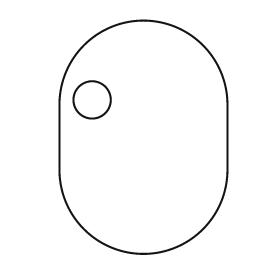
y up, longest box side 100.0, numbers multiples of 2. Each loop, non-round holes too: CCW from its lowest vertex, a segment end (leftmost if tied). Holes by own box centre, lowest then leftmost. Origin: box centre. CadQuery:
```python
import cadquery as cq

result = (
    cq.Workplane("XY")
    .moveTo(-36.0, -14.0)
    .threePointArc((0.0, -50.0), (36.0, -14.0))
    .lineTo(36.0, 14.0)
    .threePointArc((0.0, 50.0), (-36.0, 14.0))
    .close()
    .moveTo(-22.0, 16.0)
    .circle(8.0)
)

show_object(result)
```